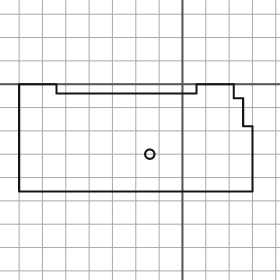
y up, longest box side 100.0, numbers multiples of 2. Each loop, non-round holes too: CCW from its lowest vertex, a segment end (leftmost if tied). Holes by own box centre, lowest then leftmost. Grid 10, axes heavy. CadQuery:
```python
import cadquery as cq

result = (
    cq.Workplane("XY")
    .moveTo(-70.0, -46.0)
    .lineTo(30.0, -46.0)
    .lineTo(30.0, -18.0)
    .lineTo(26.0, -18.0)
    .lineTo(26.0, -6.0)
    .lineTo(22.0, -6.0)
    .lineTo(22.0, 0.0)
    .lineTo(6.0, 0.0)
    .lineTo(6.0, -4.0)
    .lineTo(-54.0, -4.0)
    .lineTo(-54.0, 0.0)
    .lineTo(-70.0, 0.0)
    .close()
    .moveTo(-14.0, -30.0)
    .circle(2.0)
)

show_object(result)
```